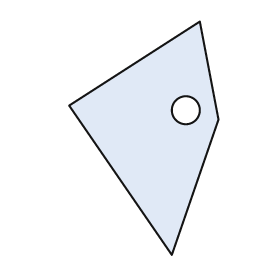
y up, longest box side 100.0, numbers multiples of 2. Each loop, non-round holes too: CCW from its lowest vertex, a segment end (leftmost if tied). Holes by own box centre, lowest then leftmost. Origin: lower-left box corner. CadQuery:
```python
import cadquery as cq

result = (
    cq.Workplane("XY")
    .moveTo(44.0, 0.0)
    .lineTo(64.0, 58.0)
    .lineTo(56.0, 100.0)
    .lineTo(0.0, 64.0)
    .close()
    .moveTo(50.0, 62.0)
    .circle(6.0)
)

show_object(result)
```